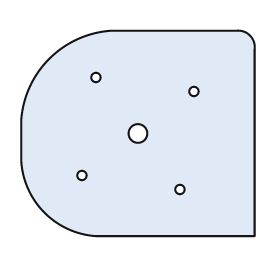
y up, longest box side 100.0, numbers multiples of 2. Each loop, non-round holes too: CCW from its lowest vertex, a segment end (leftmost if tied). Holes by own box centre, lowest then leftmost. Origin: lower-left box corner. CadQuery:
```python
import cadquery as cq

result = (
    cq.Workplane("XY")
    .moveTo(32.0, 0.0)
    .lineTo(100.0, 0.0)
    .lineTo(100.0, 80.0)
    .threePointArc((98.0, 86.0), (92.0, 88.0))
    .lineTo(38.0, 88.0)
    .threePointArc((12.0, 76.0), (0.0, 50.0))
    .lineTo(0.0, 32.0)
    .threePointArc((10.0, 10.0), (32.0, 0.0))
    .close()
    .moveTo(68.0, 20.0)
    .circle(2.0)
    .moveTo(26.0, 26.0)
    .circle(2.0)
    .moveTo(50.0, 44.0)
    .circle(4.0)
    .moveTo(74.0, 62.0)
    .circle(2.0)
    .moveTo(32.0, 68.0)
    .circle(2.0)
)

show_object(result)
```